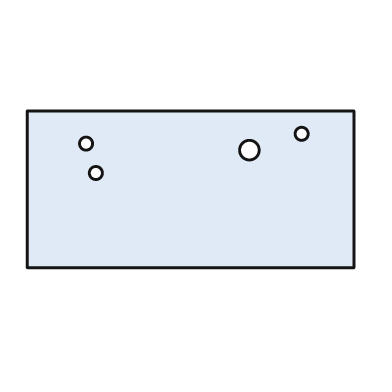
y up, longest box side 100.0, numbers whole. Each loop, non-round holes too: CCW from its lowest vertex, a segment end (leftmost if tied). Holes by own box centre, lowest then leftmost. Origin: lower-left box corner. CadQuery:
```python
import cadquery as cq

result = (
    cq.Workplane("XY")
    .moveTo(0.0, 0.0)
    .lineTo(100.0, 0.0)
    .lineTo(100.0, 48.0)
    .lineTo(0.0, 48.0)
    .close()
    .moveTo(21.0, 29.0)
    .circle(2.0)
    .moveTo(68.0, 36.0)
    .circle(3.0)
    .moveTo(18.0, 38.0)
    .circle(2.0)
    .moveTo(84.0, 41.0)
    .circle(2.0)
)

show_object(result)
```